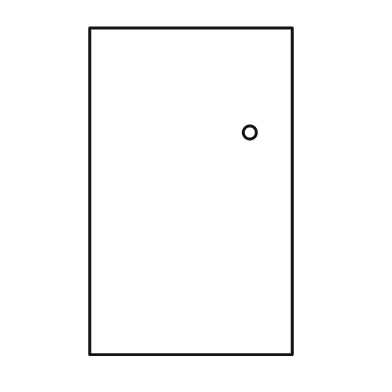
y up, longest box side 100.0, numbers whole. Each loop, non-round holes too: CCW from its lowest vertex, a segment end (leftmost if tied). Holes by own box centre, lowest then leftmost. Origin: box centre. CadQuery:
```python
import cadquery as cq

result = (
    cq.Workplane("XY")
    .moveTo(-31.0, -50.0)
    .lineTo(31.0, -50.0)
    .lineTo(31.0, 50.0)
    .lineTo(-31.0, 50.0)
    .close()
    .moveTo(18.0, 18.0)
    .circle(2.0)
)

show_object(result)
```